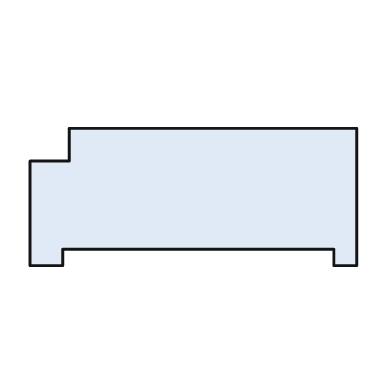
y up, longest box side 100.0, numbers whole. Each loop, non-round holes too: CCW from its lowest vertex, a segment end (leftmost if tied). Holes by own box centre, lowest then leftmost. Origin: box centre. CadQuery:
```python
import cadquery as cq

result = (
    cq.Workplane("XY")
    .moveTo(-50.0, -21.0)
    .lineTo(-40.0, -21.0)
    .lineTo(-40.0, -16.0)
    .lineTo(43.0, -16.0)
    .lineTo(43.0, -21.0)
    .lineTo(50.0, -21.0)
    .lineTo(50.0, 21.0)
    .lineTo(-38.0, 21.0)
    .lineTo(-38.0, 11.0)
    .lineTo(-50.0, 11.0)
    .close()
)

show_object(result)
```